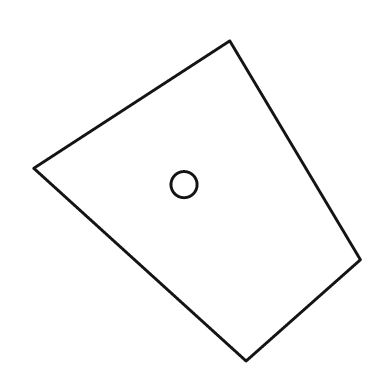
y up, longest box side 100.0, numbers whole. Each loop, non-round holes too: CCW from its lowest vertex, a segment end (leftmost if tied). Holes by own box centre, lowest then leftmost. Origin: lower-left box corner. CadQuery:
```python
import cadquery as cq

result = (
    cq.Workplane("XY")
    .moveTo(65.0, 0.0)
    .lineTo(100.0, 31.0)
    .lineTo(60.0, 98.0)
    .lineTo(0.0, 59.0)
    .close()
    .moveTo(46.0, 54.0)
    .circle(4.0)
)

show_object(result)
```